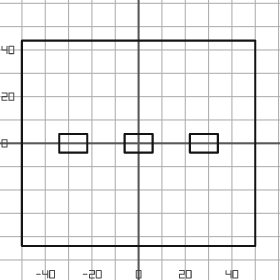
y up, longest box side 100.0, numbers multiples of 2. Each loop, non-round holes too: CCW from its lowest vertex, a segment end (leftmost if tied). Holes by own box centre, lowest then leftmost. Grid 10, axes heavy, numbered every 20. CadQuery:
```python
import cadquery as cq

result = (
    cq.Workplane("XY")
    .moveTo(-50.0, -44.0)
    .lineTo(50.0, -44.0)
    .lineTo(50.0, 44.0)
    .lineTo(-50.0, 44.0)
    .close()
    .moveTo(-34.0, -4.0)
    .lineTo(-22.0, -4.0)
    .lineTo(-22.0, 4.0)
    .lineTo(-34.0, 4.0)
    .close()
    .moveTo(-6.0, -4.0)
    .lineTo(6.0, -4.0)
    .lineTo(6.0, 4.0)
    .lineTo(-6.0, 4.0)
    .close()
    .moveTo(22.0, -4.0)
    .lineTo(34.0, -4.0)
    .lineTo(34.0, 4.0)
    .lineTo(22.0, 4.0)
    .close()
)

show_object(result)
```